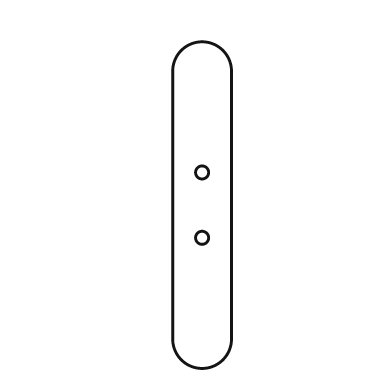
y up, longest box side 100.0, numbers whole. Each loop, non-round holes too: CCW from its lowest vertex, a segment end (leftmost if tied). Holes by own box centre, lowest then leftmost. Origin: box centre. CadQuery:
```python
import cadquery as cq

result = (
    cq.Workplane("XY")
    .moveTo(-9.0, -41.0)
    .threePointArc((0.0, -50.0), (9.0, -41.0))
    .lineTo(9.0, 41.0)
    .threePointArc((0.0, 50.0), (-9.0, 41.0))
    .close()
    .moveTo(0.0, -10.0)
    .circle(2.0)
    .moveTo(0.0, 10.0)
    .circle(2.0)
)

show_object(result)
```